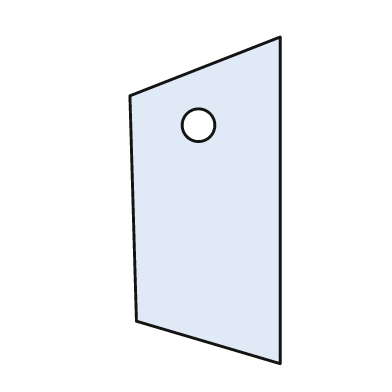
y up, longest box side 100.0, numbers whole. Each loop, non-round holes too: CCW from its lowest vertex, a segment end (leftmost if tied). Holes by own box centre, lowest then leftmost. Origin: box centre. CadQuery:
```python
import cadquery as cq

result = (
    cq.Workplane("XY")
    .moveTo(23.0, -50.0)
    .lineTo(23.0, 50.0)
    .lineTo(-23.0, 32.0)
    .lineTo(-21.0, -37.0)
    .close()
    .moveTo(-2.0, 23.0)
    .circle(5.0)
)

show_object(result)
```